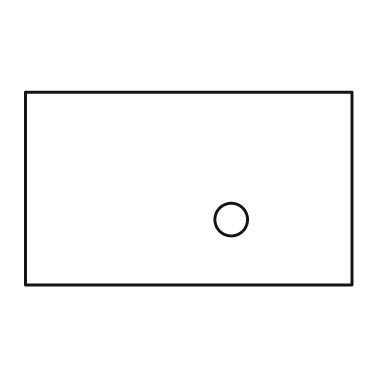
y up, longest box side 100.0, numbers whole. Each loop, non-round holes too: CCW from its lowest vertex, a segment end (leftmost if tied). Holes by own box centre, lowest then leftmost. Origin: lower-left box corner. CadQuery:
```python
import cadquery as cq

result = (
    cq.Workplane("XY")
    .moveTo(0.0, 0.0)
    .lineTo(100.0, 0.0)
    .lineTo(100.0, 59.0)
    .lineTo(0.0, 59.0)
    .close()
    .moveTo(63.0, 20.0)
    .circle(5.0)
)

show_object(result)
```